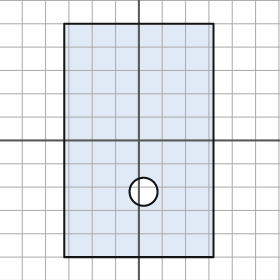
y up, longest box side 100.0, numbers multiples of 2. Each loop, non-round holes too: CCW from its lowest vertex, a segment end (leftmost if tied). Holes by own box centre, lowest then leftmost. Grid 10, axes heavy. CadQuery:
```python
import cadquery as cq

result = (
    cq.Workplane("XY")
    .moveTo(-32.0, -50.0)
    .lineTo(32.0, -50.0)
    .lineTo(32.0, 50.0)
    .lineTo(-32.0, 50.0)
    .close()
    .moveTo(2.0, -22.0)
    .circle(6.0)
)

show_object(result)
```